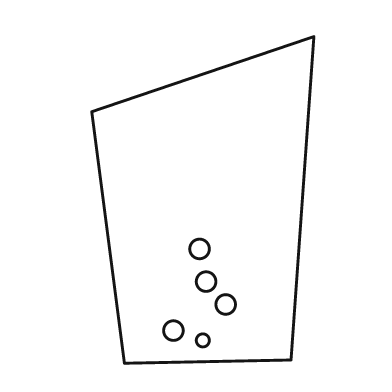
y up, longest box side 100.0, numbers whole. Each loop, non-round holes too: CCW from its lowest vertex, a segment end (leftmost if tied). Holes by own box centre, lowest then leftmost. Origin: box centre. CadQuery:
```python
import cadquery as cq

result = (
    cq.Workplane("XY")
    .moveTo(-24.0, -50.0)
    .lineTo(27.0, -49.0)
    .lineTo(34.0, 50.0)
    .lineTo(-34.0, 27.0)
    .close()
    .moveTo(0.0, -43.0)
    .circle(2.0)
    .moveTo(-9.0, -40.0)
    .circle(3.0)
    .moveTo(7.0, -32.0)
    .circle(3.0)
    .moveTo(1.0, -25.0)
    .circle(3.0)
    .moveTo(-1.0, -15.0)
    .circle(3.0)
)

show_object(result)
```